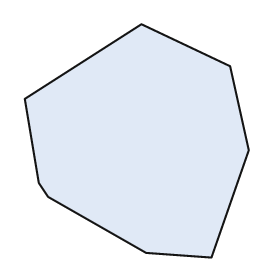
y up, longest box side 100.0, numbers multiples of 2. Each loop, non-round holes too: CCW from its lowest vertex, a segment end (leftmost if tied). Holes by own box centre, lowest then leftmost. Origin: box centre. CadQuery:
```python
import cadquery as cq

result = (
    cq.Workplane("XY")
    .moveTo(32.0, -50.0)
    .lineTo(48.0, -4.0)
    .lineTo(40.0, 32.0)
    .lineTo(2.0, 50.0)
    .lineTo(-48.0, 18.0)
    .lineTo(-42.0, -18.0)
    .lineTo(-38.0, -24.0)
    .lineTo(4.0, -48.0)
    .close()
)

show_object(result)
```